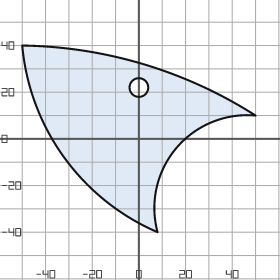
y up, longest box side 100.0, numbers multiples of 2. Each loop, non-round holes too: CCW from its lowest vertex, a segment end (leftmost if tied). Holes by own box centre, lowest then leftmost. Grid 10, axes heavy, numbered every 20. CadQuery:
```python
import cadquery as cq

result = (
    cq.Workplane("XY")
    .moveTo(8.0, -40.0)
    .threePointArc((16.0, -4.0), (50.0, 10.0))
    .threePointArc((2.0, 32.0), (-50.0, 40.0))
    .threePointArc((-32.0, -8.0), (8.0, -40.0))
    .close()
    .moveTo(0.0, 22.0)
    .circle(4.0)
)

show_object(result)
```